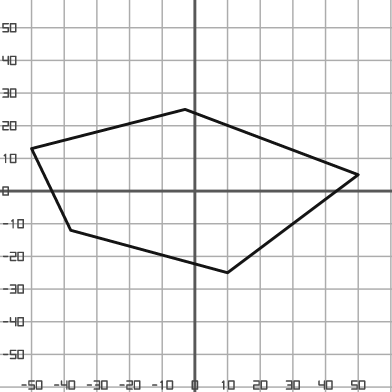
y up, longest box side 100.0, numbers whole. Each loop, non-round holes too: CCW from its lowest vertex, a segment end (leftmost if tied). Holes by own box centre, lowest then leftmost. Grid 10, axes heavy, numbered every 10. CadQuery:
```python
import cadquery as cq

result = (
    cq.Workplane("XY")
    .moveTo(10.0, -25.0)
    .lineTo(50.0, 5.0)
    .lineTo(-3.0, 25.0)
    .lineTo(-50.0, 13.0)
    .lineTo(-38.0, -12.0)
    .close()
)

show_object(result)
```